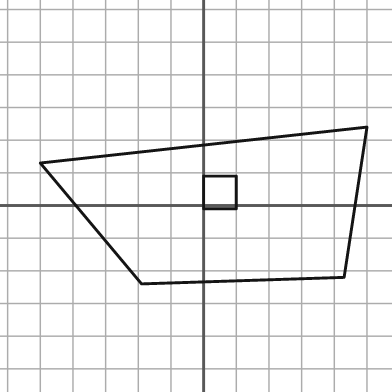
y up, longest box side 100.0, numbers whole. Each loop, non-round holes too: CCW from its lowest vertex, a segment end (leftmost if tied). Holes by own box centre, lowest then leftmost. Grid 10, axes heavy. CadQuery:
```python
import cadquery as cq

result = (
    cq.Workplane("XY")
    .moveTo(-19.0, -24.0)
    .lineTo(43.0, -22.0)
    .lineTo(50.0, 24.0)
    .lineTo(-50.0, 13.0)
    .close()
    .moveTo(0.0, -1.0)
    .lineTo(10.0, -1.0)
    .lineTo(10.0, 9.0)
    .lineTo(0.0, 9.0)
    .close()
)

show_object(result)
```